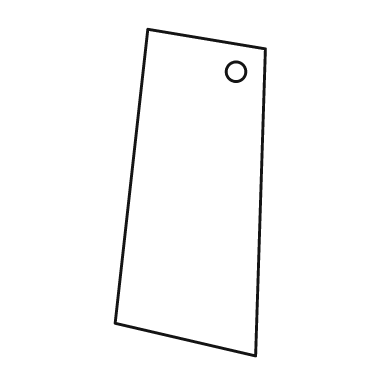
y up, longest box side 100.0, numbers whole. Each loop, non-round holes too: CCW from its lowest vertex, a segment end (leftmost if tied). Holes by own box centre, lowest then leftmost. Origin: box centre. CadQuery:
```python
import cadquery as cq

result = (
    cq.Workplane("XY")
    .moveTo(20.0, -50.0)
    .lineTo(23.0, 44.0)
    .lineTo(-13.0, 50.0)
    .lineTo(-23.0, -40.0)
    .close()
    .moveTo(14.0, 37.0)
    .circle(3.0)
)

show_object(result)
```